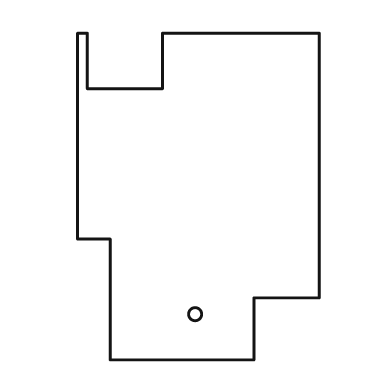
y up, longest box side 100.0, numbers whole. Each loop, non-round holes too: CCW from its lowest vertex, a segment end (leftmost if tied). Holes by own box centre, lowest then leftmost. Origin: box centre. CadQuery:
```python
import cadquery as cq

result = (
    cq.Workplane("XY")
    .moveTo(-27.0, -50.0)
    .lineTo(17.0, -50.0)
    .lineTo(17.0, -31.0)
    .lineTo(37.0, -31.0)
    .lineTo(37.0, 50.0)
    .lineTo(-11.0, 50.0)
    .lineTo(-11.0, 33.0)
    .lineTo(-34.0, 33.0)
    .lineTo(-34.0, 50.0)
    .lineTo(-37.0, 50.0)
    .lineTo(-37.0, -13.0)
    .lineTo(-27.0, -13.0)
    .close()
    .moveTo(-1.0, -36.0)
    .circle(2.0)
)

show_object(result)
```